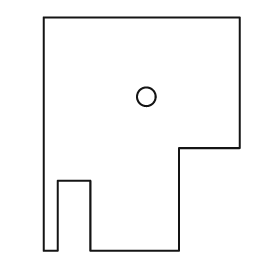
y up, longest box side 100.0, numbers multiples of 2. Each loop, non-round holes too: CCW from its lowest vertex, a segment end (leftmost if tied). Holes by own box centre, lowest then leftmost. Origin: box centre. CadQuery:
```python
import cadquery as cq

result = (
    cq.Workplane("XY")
    .moveTo(-42.0, -50.0)
    .lineTo(-36.0, -50.0)
    .lineTo(-36.0, -20.0)
    .lineTo(-22.0, -20.0)
    .lineTo(-22.0, -50.0)
    .lineTo(16.0, -50.0)
    .lineTo(16.0, -6.0)
    .lineTo(42.0, -6.0)
    .lineTo(42.0, 50.0)
    .lineTo(-42.0, 50.0)
    .close()
    .moveTo(2.0, 16.0)
    .circle(4.0)
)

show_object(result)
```